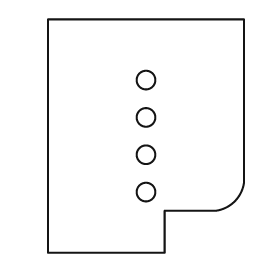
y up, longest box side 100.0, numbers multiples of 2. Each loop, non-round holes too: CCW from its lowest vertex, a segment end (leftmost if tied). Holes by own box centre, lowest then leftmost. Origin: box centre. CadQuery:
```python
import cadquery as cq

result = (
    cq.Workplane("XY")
    .moveTo(-42.0, -50.0)
    .lineTo(8.0, -50.0)
    .lineTo(8.0, -32.0)
    .lineTo(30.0, -32.0)
    .threePointArc((38.0, -28.0), (42.0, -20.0))
    .lineTo(42.0, 50.0)
    .lineTo(-42.0, 50.0)
    .close()
    .moveTo(0.0, -24.0)
    .circle(4.0)
    .moveTo(0.0, -8.0)
    .circle(4.0)
    .moveTo(0.0, 8.0)
    .circle(4.0)
    .moveTo(0.0, 24.0)
    .circle(4.0)
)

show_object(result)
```